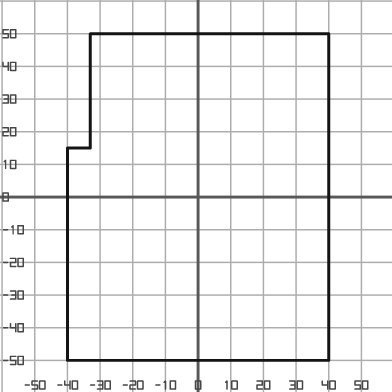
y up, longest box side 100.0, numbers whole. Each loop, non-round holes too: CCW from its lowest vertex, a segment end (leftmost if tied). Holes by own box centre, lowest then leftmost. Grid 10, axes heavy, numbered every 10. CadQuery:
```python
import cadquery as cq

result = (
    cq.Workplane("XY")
    .moveTo(-40.0, -50.0)
    .lineTo(40.0, -50.0)
    .lineTo(40.0, 50.0)
    .lineTo(-33.0, 50.0)
    .lineTo(-33.0, 15.0)
    .lineTo(-40.0, 15.0)
    .close()
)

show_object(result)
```